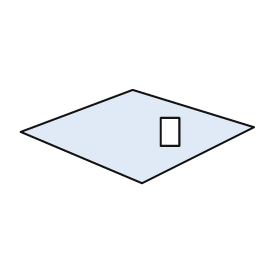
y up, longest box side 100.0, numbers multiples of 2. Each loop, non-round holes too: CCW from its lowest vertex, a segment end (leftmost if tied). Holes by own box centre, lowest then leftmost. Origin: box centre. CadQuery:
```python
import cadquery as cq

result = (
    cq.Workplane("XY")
    .moveTo(2.0, -20.0)
    .lineTo(50.0, 4.0)
    .lineTo(-2.0, 20.0)
    .lineTo(-50.0, 2.0)
    .close()
    .moveTo(10.0, -4.0)
    .lineTo(18.0, -4.0)
    .lineTo(18.0, 8.0)
    .lineTo(10.0, 8.0)
    .close()
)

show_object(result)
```